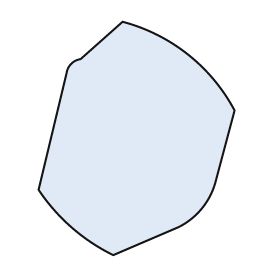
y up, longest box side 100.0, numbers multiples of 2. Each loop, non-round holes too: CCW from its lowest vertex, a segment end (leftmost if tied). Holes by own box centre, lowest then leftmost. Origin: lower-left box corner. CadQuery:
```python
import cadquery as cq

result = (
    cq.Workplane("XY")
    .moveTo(32.0, 0.0)
    .lineTo(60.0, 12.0)
    .threePointArc((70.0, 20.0), (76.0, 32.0))
    .lineTo(84.0, 62.0)
    .threePointArc((64.0, 86.0), (36.0, 100.0))
    .lineTo(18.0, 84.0)
    .threePointArc((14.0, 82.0), (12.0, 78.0))
    .lineTo(0.0, 28.0)
    .threePointArc((14.0, 12.0), (32.0, 0.0))
    .close()
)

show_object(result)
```